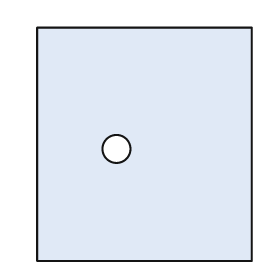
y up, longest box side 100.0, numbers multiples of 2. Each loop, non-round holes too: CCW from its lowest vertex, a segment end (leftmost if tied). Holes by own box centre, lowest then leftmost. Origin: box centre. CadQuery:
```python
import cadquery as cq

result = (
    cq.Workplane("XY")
    .moveTo(-46.0, -50.0)
    .lineTo(46.0, -50.0)
    .lineTo(46.0, 50.0)
    .lineTo(-46.0, 50.0)
    .close()
    .moveTo(-12.0, -2.0)
    .circle(6.0)
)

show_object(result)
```